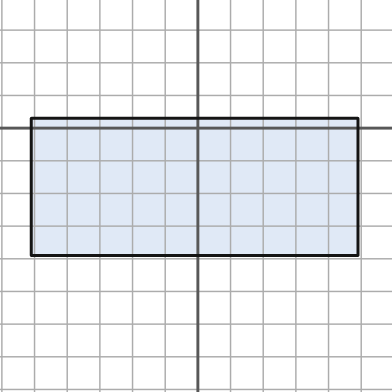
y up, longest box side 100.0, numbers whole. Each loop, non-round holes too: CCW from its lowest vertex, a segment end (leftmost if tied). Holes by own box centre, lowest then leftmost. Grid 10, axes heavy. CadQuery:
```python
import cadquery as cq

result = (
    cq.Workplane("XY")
    .moveTo(-51.0, -39.0)
    .lineTo(49.0, -39.0)
    .lineTo(49.0, 3.0)
    .lineTo(-51.0, 3.0)
    .close()
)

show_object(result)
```